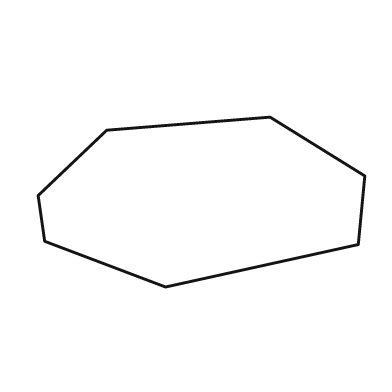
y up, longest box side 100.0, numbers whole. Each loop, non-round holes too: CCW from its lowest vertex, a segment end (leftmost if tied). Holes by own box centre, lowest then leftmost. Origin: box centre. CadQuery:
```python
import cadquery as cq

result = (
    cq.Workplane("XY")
    .moveTo(-11.0, -26.0)
    .lineTo(48.0, -13.0)
    .lineTo(50.0, 8.0)
    .lineTo(21.0, 26.0)
    .lineTo(-29.0, 22.0)
    .lineTo(-50.0, 2.0)
    .lineTo(-48.0, -12.0)
    .close()
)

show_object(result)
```